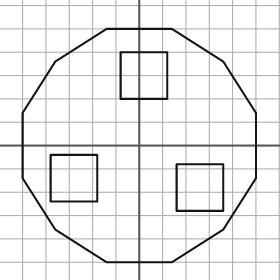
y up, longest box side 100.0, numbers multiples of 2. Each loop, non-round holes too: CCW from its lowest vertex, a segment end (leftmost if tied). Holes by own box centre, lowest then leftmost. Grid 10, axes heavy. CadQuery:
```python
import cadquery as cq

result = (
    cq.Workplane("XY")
    .moveTo(-14.0, -50.0)
    .lineTo(14.0, -50.0)
    .lineTo(36.0, -36.0)
    .lineTo(50.0, -14.0)
    .lineTo(50.0, 14.0)
    .lineTo(36.0, 36.0)
    .lineTo(14.0, 50.0)
    .lineTo(-14.0, 50.0)
    .lineTo(-36.0, 36.0)
    .lineTo(-50.0, 14.0)
    .lineTo(-50.0, -14.0)
    .lineTo(-36.0, -36.0)
    .close()
    .moveTo(16.0, -28.0)
    .lineTo(36.0, -28.0)
    .lineTo(36.0, -8.0)
    .lineTo(16.0, -8.0)
    .close()
    .moveTo(-38.0, -24.0)
    .lineTo(-18.0, -24.0)
    .lineTo(-18.0, -4.0)
    .lineTo(-38.0, -4.0)
    .close()
    .moveTo(-8.0, 20.0)
    .lineTo(12.0, 20.0)
    .lineTo(12.0, 40.0)
    .lineTo(-8.0, 40.0)
    .close()
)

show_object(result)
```